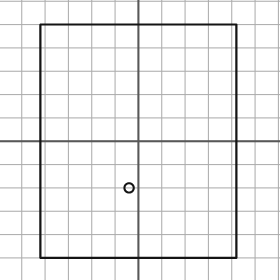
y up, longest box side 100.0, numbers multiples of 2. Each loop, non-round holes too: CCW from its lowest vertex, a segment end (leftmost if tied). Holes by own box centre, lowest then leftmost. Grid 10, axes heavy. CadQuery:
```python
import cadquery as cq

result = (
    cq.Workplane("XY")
    .moveTo(-42.0, -50.0)
    .lineTo(42.0, -50.0)
    .lineTo(42.0, 50.0)
    .lineTo(-42.0, 50.0)
    .close()
    .moveTo(-4.0, -20.0)
    .circle(2.0)
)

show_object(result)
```